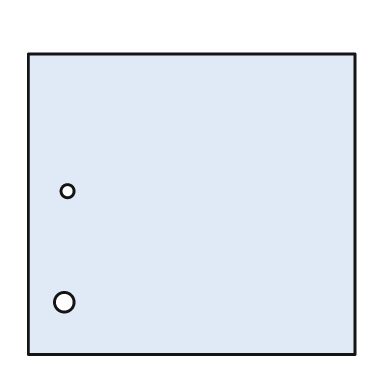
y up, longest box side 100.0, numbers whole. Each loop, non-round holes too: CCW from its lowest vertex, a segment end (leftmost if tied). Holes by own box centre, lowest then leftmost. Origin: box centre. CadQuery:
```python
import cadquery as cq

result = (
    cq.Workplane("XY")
    .moveTo(-50.0, -46.0)
    .lineTo(50.0, -46.0)
    .lineTo(50.0, 46.0)
    .lineTo(-50.0, 46.0)
    .close()
    .moveTo(-39.0, -30.0)
    .circle(3.0)
    .moveTo(-38.0, 4.0)
    .circle(2.0)
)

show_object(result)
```